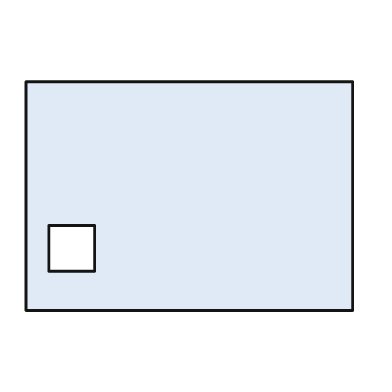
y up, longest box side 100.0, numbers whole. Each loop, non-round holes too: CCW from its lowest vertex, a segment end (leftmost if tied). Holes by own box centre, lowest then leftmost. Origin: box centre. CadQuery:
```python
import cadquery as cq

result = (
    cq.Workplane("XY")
    .moveTo(-50.0, -35.0)
    .lineTo(50.0, -35.0)
    .lineTo(50.0, 35.0)
    .lineTo(-50.0, 35.0)
    .close()
    .moveTo(-43.0, -23.0)
    .lineTo(-29.0, -23.0)
    .lineTo(-29.0, -9.0)
    .lineTo(-43.0, -9.0)
    .close()
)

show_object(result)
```